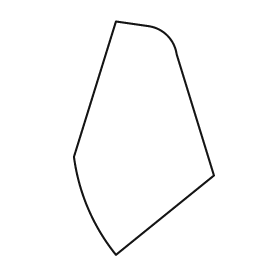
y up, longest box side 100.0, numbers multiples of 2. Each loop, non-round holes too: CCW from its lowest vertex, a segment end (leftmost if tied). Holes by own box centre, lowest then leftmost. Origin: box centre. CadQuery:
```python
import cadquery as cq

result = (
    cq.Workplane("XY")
    .moveTo(-12.0, -50.0)
    .lineTo(30.0, -16.0)
    .lineTo(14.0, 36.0)
    .threePointArc((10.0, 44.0), (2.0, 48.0))
    .lineTo(-12.0, 50.0)
    .lineTo(-30.0, -8.0)
    .threePointArc((-24.0, -30.0), (-12.0, -50.0))
    .close()
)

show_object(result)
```